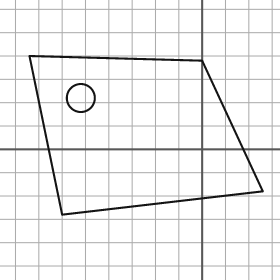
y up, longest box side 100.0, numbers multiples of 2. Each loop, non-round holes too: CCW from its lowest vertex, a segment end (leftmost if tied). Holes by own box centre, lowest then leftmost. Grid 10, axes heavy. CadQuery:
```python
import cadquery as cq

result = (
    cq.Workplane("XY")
    .moveTo(-60.0, -28.0)
    .lineTo(26.0, -18.0)
    .lineTo(0.0, 38.0)
    .lineTo(-74.0, 40.0)
    .close()
    .moveTo(-52.0, 22.0)
    .circle(6.0)
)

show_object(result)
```